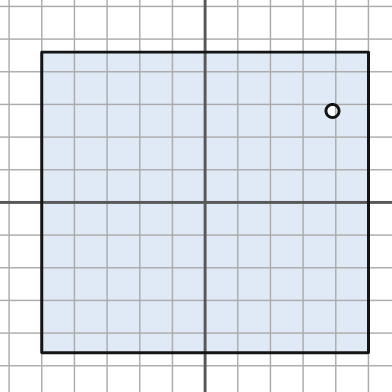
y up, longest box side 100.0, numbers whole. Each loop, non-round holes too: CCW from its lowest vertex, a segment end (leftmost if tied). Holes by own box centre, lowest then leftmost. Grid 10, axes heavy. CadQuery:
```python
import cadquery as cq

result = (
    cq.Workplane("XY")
    .moveTo(-50.0, -46.0)
    .lineTo(50.0, -46.0)
    .lineTo(50.0, 46.0)
    .lineTo(-50.0, 46.0)
    .close()
    .moveTo(39.0, 28.0)
    .circle(2.0)
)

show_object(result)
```